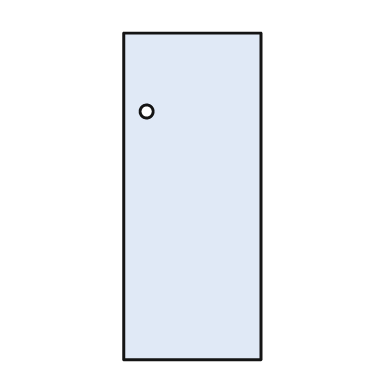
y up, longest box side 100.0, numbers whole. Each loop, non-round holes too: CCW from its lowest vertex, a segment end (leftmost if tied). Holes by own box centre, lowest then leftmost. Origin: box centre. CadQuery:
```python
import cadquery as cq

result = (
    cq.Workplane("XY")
    .moveTo(-21.0, -50.0)
    .lineTo(21.0, -50.0)
    .lineTo(21.0, 50.0)
    .lineTo(-21.0, 50.0)
    .close()
    .moveTo(-14.0, 26.0)
    .circle(2.0)
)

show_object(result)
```